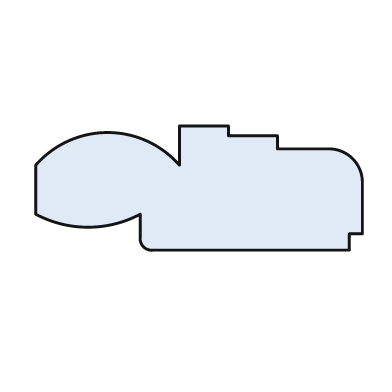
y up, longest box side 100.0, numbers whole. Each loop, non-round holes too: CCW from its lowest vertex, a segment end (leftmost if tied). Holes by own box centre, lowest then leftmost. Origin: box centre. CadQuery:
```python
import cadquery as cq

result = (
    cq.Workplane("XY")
    .moveTo(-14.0, -19.0)
    .lineTo(46.0, -19.0)
    .lineTo(46.0, -14.0)
    .lineTo(50.0, -14.0)
    .lineTo(50.0, 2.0)
    .threePointArc((47.0, 9.0), (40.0, 12.0))
    .lineTo(24.0, 12.0)
    .lineTo(24.0, 16.0)
    .lineTo(9.0, 16.0)
    .lineTo(9.0, 19.0)
    .lineTo(-6.0, 19.0)
    .lineTo(-6.0, 7.0)
    .threePointArc((-28.0, 17.0), (-50.0, 7.0))
    .lineTo(-50.0, -8.0)
    .threePointArc((-34.0, -12.0), (-18.0, -8.0))
    .lineTo(-18.0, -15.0)
    .threePointArc((-17.0, -18.0), (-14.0, -19.0))
    .close()
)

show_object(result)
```